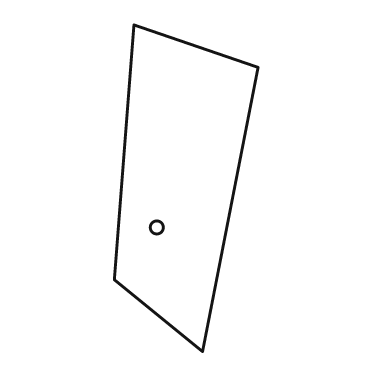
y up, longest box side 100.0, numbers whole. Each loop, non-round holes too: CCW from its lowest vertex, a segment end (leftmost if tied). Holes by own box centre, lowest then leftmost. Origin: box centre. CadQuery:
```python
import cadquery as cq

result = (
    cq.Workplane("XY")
    .moveTo(5.0, -50.0)
    .lineTo(22.0, 37.0)
    .lineTo(-16.0, 50.0)
    .lineTo(-22.0, -28.0)
    .close()
    .moveTo(-9.0, -12.0)
    .circle(2.0)
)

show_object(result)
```